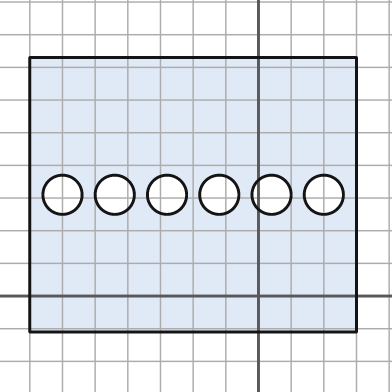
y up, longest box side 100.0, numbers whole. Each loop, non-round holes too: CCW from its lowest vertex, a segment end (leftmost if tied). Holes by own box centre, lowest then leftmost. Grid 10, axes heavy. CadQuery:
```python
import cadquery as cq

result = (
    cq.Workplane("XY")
    .moveTo(-70.0, -11.0)
    .lineTo(30.0, -11.0)
    .lineTo(30.0, 73.0)
    .lineTo(-70.0, 73.0)
    .close()
    .moveTo(-60.0, 31.0)
    .circle(6.0)
    .moveTo(-44.0, 31.0)
    .circle(6.0)
    .moveTo(-28.0, 31.0)
    .circle(6.0)
    .moveTo(-12.0, 31.0)
    .circle(6.0)
    .moveTo(4.0, 31.0)
    .circle(6.0)
    .moveTo(20.0, 31.0)
    .circle(6.0)
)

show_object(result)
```